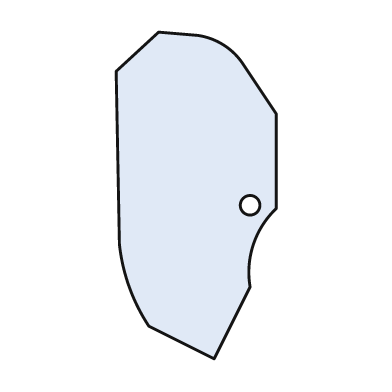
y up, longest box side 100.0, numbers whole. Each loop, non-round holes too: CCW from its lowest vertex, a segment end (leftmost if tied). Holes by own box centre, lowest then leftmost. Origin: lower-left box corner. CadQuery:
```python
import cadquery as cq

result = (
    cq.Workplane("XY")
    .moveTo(30.0, 0.0)
    .lineTo(41.0, 22.0)
    .threePointArc((42.0, 35.0), (49.0, 46.0))
    .lineTo(49.0, 75.0)
    .lineTo(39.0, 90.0)
    .threePointArc((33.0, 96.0), (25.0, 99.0))
    .lineTo(13.0, 100.0)
    .lineTo(0.0, 88.0)
    .lineTo(1.0, 35.0)
    .threePointArc((4.0, 22.0), (10.0, 10.0))
    .close()
    .moveTo(41.0, 47.0)
    .circle(3.0)
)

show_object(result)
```